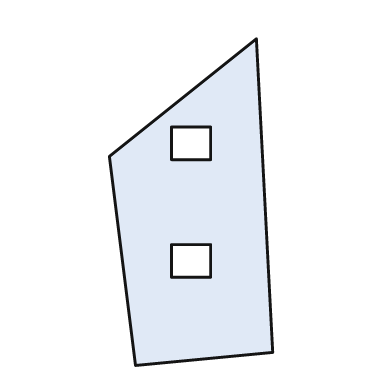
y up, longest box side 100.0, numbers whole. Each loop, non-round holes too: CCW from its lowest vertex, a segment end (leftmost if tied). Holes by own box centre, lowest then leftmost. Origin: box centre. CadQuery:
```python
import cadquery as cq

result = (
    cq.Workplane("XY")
    .moveTo(-17.0, -50.0)
    .lineTo(25.0, -46.0)
    .lineTo(20.0, 50.0)
    .lineTo(-25.0, 14.0)
    .close()
    .moveTo(-6.0, -23.0)
    .lineTo(6.0, -23.0)
    .lineTo(6.0, -13.0)
    .lineTo(-6.0, -13.0)
    .close()
    .moveTo(-6.0, 13.0)
    .lineTo(6.0, 13.0)
    .lineTo(6.0, 23.0)
    .lineTo(-6.0, 23.0)
    .close()
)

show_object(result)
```